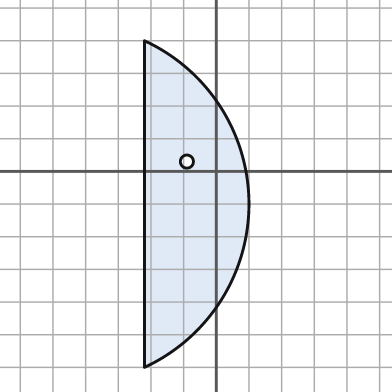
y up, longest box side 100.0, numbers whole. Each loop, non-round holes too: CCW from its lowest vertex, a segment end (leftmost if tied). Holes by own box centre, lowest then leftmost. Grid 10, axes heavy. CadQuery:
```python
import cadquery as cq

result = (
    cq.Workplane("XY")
    .moveTo(-22.0, -60.0)
    .threePointArc((10.0, -10.0), (-22.0, 40.0))
    .close()
    .moveTo(-9.0, 3.0)
    .circle(2.0)
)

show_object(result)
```